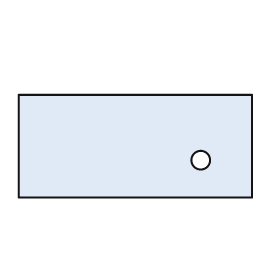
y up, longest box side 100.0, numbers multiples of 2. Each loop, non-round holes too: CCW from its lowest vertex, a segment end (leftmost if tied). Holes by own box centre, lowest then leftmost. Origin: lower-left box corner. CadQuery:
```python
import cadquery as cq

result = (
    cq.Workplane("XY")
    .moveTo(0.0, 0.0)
    .lineTo(100.0, 0.0)
    .lineTo(100.0, 44.0)
    .lineTo(0.0, 44.0)
    .close()
    .moveTo(78.0, 16.0)
    .circle(4.0)
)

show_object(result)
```